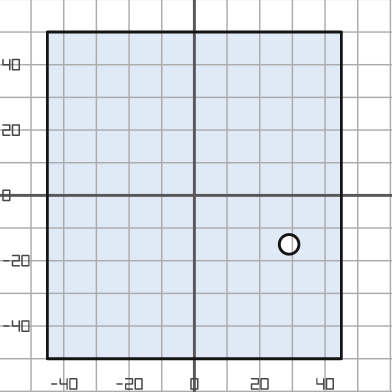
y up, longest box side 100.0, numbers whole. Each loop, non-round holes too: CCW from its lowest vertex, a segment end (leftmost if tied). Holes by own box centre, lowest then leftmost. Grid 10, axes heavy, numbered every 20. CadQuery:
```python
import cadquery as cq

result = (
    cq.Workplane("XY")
    .moveTo(-45.0, -50.0)
    .lineTo(45.0, -50.0)
    .lineTo(45.0, 50.0)
    .lineTo(-45.0, 50.0)
    .close()
    .moveTo(29.0, -15.0)
    .circle(3.0)
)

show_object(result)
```